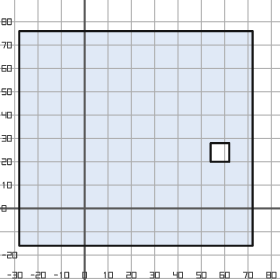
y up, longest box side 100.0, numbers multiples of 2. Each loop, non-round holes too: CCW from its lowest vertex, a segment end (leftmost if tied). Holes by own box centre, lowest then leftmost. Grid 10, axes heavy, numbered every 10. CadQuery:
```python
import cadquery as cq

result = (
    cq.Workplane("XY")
    .moveTo(-28.0, -16.0)
    .lineTo(72.0, -16.0)
    .lineTo(72.0, 76.0)
    .lineTo(-28.0, 76.0)
    .close()
    .moveTo(54.0, 20.0)
    .lineTo(62.0, 20.0)
    .lineTo(62.0, 28.0)
    .lineTo(54.0, 28.0)
    .close()
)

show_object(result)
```